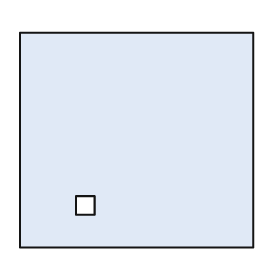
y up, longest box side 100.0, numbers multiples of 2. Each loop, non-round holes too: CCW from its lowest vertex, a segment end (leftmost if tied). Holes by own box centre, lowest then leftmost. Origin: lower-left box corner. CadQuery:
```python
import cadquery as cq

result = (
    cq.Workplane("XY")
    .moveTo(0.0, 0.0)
    .lineTo(100.0, 0.0)
    .lineTo(100.0, 92.0)
    .lineTo(0.0, 92.0)
    .close()
    .moveTo(24.0, 14.0)
    .lineTo(32.0, 14.0)
    .lineTo(32.0, 22.0)
    .lineTo(24.0, 22.0)
    .close()
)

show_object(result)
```